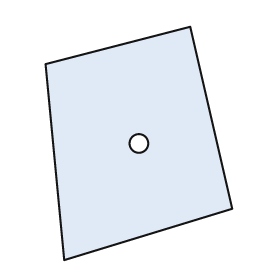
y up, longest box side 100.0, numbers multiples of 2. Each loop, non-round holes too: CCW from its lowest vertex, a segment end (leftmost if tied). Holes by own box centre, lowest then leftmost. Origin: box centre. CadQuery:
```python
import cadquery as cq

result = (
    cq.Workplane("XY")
    .moveTo(-32.0, -50.0)
    .lineTo(40.0, -28.0)
    .lineTo(22.0, 50.0)
    .lineTo(-40.0, 34.0)
    .close()
    .moveTo(0.0, 0.0)
    .circle(4.0)
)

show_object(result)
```